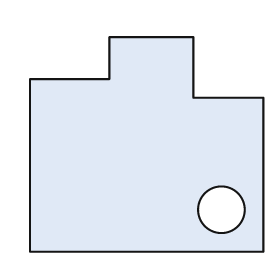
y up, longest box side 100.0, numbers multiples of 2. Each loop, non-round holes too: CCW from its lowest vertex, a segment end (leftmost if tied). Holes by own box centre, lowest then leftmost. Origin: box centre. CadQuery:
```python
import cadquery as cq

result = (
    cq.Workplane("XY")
    .moveTo(-50.0, -46.0)
    .lineTo(50.0, -46.0)
    .lineTo(50.0, 20.0)
    .lineTo(20.0, 20.0)
    .lineTo(20.0, 46.0)
    .lineTo(-16.0, 46.0)
    .lineTo(-16.0, 28.0)
    .lineTo(-50.0, 28.0)
    .close()
    .moveTo(32.0, -28.0)
    .circle(10.0)
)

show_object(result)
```